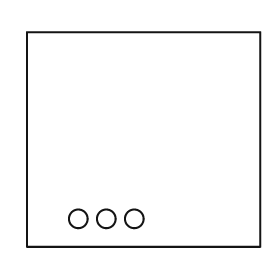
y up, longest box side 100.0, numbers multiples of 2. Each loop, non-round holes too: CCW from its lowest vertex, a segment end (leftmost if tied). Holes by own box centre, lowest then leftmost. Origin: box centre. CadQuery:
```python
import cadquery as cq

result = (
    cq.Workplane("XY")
    .moveTo(-50.0, -46.0)
    .lineTo(50.0, -46.0)
    .lineTo(50.0, 46.0)
    .lineTo(-50.0, 46.0)
    .close()
    .moveTo(-28.0, -34.0)
    .circle(4.0)
    .moveTo(-16.0, -34.0)
    .circle(4.0)
    .moveTo(-4.0, -34.0)
    .circle(4.0)
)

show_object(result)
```